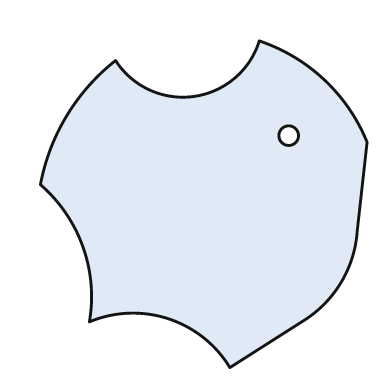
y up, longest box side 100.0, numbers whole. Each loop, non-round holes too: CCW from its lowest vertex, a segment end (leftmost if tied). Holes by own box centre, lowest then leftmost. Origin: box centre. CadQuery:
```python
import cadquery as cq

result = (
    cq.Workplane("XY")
    .moveTo(8.0, -50.0)
    .lineTo(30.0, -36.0)
    .threePointArc((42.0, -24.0), (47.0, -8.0))
    .lineTo(50.0, 19.0)
    .threePointArc((37.0, 38.0), (17.0, 50.0))
    .threePointArc((-3.0, 33.0), (-27.0, 44.0))
    .threePointArc((-42.0, 27.0), (-50.0, 6.0))
    .threePointArc((-37.0, -13.0), (-35.0, -36.0))
    .threePointArc((-11.0, -35.0), (8.0, -50.0))
    .close()
    .moveTo(26.0, 21.0)
    .circle(3.0)
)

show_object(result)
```